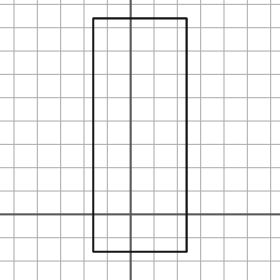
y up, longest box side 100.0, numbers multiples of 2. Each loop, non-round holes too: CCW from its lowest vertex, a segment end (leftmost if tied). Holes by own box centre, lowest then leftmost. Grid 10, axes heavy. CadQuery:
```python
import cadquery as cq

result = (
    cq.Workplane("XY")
    .moveTo(-16.0, -16.0)
    .lineTo(24.0, -16.0)
    .lineTo(24.0, 84.0)
    .lineTo(-16.0, 84.0)
    .close()
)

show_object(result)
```